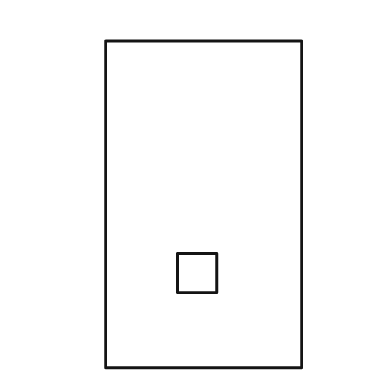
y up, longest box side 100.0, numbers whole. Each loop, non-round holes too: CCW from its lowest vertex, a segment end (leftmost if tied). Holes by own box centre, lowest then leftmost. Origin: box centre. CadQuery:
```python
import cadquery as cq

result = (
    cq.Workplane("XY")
    .moveTo(-30.0, -50.0)
    .lineTo(30.0, -50.0)
    .lineTo(30.0, 50.0)
    .lineTo(-30.0, 50.0)
    .close()
    .moveTo(-8.0, -27.0)
    .lineTo(4.0, -27.0)
    .lineTo(4.0, -15.0)
    .lineTo(-8.0, -15.0)
    .close()
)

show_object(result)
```